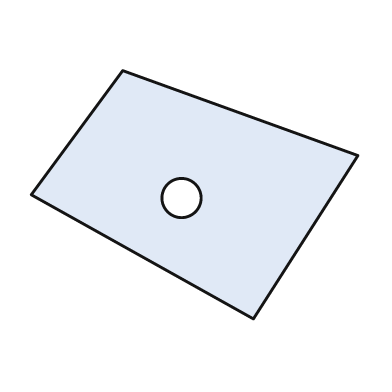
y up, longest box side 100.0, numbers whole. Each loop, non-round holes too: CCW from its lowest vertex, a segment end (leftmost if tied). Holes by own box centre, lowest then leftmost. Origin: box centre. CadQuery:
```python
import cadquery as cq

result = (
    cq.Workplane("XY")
    .moveTo(18.0, -38.0)
    .lineTo(50.0, 12.0)
    .lineTo(-22.0, 38.0)
    .lineTo(-50.0, 0.0)
    .close()
    .moveTo(-4.0, -1.0)
    .circle(6.0)
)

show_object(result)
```